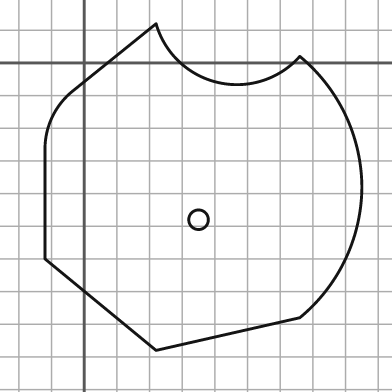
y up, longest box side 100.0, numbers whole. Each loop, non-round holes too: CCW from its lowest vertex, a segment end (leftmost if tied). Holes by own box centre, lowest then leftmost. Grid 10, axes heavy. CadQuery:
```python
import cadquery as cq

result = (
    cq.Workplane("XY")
    .moveTo(22.0, -88.0)
    .lineTo(66.0, -78.0)
    .threePointArc((80.0, -60.0), (85.0, -38.0))
    .threePointArc((80.0, -16.0), (66.0, 2.0))
    .threePointArc((41.0, -6.0), (22.0, 12.0))
    .lineTo(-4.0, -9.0)
    .threePointArc((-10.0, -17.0), (-12.0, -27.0))
    .lineTo(-12.0, -60.0)
    .close()
    .moveTo(35.0, -48.0)
    .circle(3.0)
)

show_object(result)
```